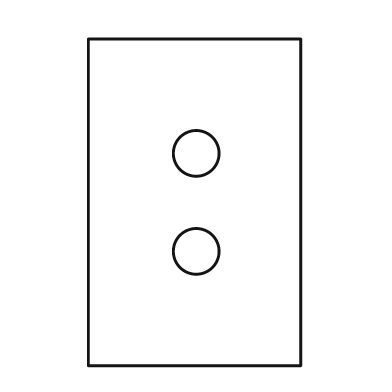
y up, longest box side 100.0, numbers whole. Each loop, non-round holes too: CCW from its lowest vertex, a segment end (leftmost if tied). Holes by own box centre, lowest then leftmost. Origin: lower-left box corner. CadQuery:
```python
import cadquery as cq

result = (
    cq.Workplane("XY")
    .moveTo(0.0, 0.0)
    .lineTo(65.0, 0.0)
    .lineTo(65.0, 100.0)
    .lineTo(0.0, 100.0)
    .close()
    .moveTo(33.0, 35.0)
    .circle(7.0)
    .moveTo(33.0, 65.0)
    .circle(7.0)
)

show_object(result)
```